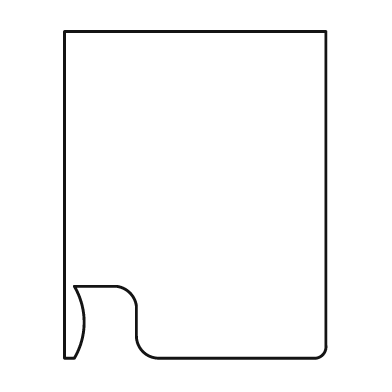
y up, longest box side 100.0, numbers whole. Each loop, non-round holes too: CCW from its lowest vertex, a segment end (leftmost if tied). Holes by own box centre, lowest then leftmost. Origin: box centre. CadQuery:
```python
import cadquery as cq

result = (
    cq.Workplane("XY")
    .moveTo(-40.0, -50.0)
    .lineTo(-37.0, -50.0)
    .threePointArc((-34.0, -39.0), (-37.0, -28.0))
    .lineTo(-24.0, -28.0)
    .threePointArc((-20.0, -30.0), (-18.0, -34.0))
    .lineTo(-18.0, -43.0)
    .threePointArc((-16.0, -48.0), (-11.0, -50.0))
    .lineTo(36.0, -50.0)
    .threePointArc((39.0, -49.0), (40.0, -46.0))
    .lineTo(40.0, 50.0)
    .lineTo(-40.0, 50.0)
    .close()
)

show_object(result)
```